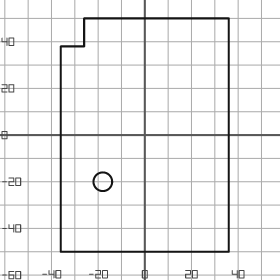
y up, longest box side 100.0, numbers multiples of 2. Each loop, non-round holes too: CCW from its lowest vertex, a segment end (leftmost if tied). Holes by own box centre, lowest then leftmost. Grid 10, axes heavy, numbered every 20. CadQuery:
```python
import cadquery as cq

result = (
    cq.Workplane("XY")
    .moveTo(-36.0, -50.0)
    .lineTo(36.0, -50.0)
    .lineTo(36.0, 50.0)
    .lineTo(-26.0, 50.0)
    .lineTo(-26.0, 38.0)
    .lineTo(-36.0, 38.0)
    .close()
    .moveTo(-18.0, -20.0)
    .circle(4.0)
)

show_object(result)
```